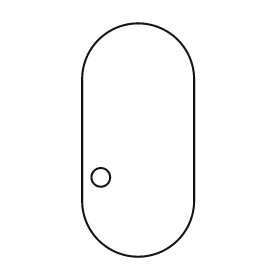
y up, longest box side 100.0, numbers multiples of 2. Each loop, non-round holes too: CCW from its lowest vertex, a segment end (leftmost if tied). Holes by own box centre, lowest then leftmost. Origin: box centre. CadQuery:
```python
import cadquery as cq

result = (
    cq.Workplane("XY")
    .moveTo(-24.0, -26.0)
    .threePointArc((0.0, -50.0), (24.0, -26.0))
    .lineTo(24.0, 26.0)
    .threePointArc((0.0, 50.0), (-24.0, 26.0))
    .close()
    .moveTo(-16.0, -16.0)
    .circle(4.0)
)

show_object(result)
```